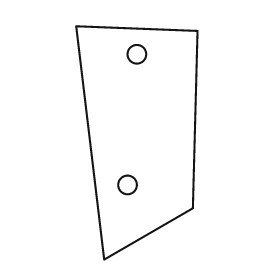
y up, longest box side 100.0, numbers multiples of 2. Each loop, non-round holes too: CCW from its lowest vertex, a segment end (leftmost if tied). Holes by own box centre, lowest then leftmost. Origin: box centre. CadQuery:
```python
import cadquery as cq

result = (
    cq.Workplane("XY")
    .moveTo(-14.0, -50.0)
    .lineTo(24.0, -28.0)
    .lineTo(26.0, 48.0)
    .lineTo(-26.0, 50.0)
    .close()
    .moveTo(-4.0, -18.0)
    .circle(4.0)
    .moveTo(0.0, 38.0)
    .circle(4.0)
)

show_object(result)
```